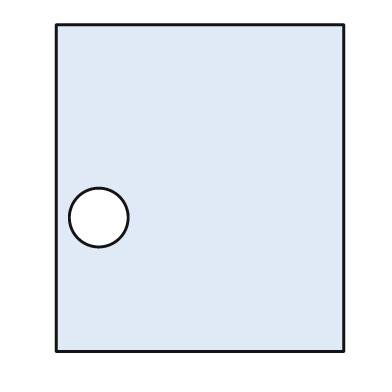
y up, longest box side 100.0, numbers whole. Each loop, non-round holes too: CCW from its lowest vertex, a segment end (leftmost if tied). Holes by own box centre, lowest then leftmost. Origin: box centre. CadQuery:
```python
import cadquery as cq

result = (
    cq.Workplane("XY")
    .moveTo(-44.0, -50.0)
    .lineTo(44.0, -50.0)
    .lineTo(44.0, 50.0)
    .lineTo(-44.0, 50.0)
    .close()
    .moveTo(-31.0, -9.0)
    .circle(9.0)
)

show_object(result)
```